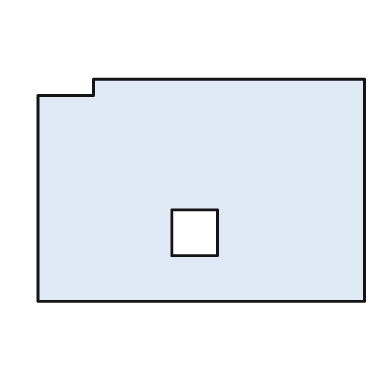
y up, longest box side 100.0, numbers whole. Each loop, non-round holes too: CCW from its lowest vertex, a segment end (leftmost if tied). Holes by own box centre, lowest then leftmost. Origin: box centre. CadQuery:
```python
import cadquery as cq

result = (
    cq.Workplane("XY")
    .moveTo(-50.0, -34.0)
    .lineTo(50.0, -34.0)
    .lineTo(50.0, 34.0)
    .lineTo(-33.0, 34.0)
    .lineTo(-33.0, 29.0)
    .lineTo(-50.0, 29.0)
    .close()
    .moveTo(-9.0, -20.0)
    .lineTo(5.0, -20.0)
    .lineTo(5.0, -6.0)
    .lineTo(-9.0, -6.0)
    .close()
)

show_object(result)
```